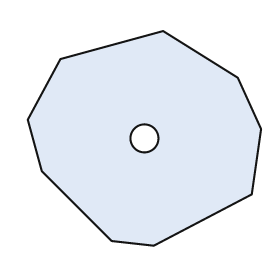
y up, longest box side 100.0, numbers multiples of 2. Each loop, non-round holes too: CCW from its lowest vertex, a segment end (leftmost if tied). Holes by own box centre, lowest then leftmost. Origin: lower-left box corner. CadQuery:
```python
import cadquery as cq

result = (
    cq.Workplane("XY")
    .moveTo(54.0, 0.0)
    .lineTo(96.0, 22.0)
    .lineTo(100.0, 50.0)
    .lineTo(90.0, 72.0)
    .lineTo(58.0, 92.0)
    .lineTo(14.0, 80.0)
    .lineTo(0.0, 54.0)
    .lineTo(6.0, 32.0)
    .lineTo(36.0, 2.0)
    .close()
    .moveTo(50.0, 46.0)
    .circle(6.0)
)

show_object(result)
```